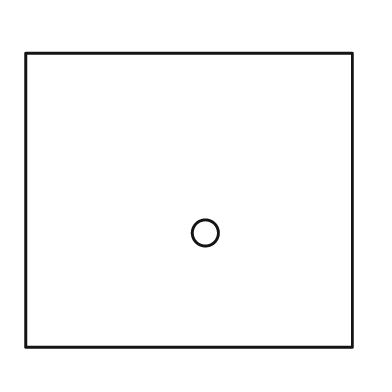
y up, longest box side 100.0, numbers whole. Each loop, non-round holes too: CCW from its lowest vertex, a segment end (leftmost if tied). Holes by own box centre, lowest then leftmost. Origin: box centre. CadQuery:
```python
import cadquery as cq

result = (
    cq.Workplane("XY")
    .moveTo(-50.0, -45.0)
    .lineTo(50.0, -45.0)
    .lineTo(50.0, 45.0)
    .lineTo(-50.0, 45.0)
    .close()
    .moveTo(5.0, -10.0)
    .circle(4.0)
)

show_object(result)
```